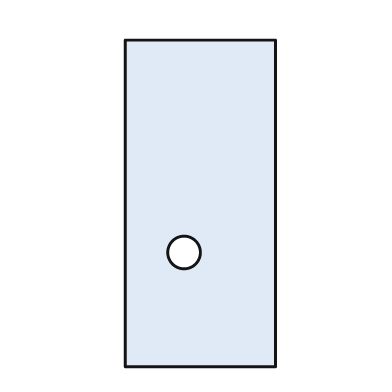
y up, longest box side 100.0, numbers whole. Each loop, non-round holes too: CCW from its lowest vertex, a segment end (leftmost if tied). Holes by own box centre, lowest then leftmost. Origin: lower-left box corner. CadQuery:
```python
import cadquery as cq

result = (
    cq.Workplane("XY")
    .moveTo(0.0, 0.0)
    .lineTo(46.0, 0.0)
    .lineTo(46.0, 100.0)
    .lineTo(0.0, 100.0)
    .close()
    .moveTo(18.0, 35.0)
    .circle(5.0)
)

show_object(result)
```